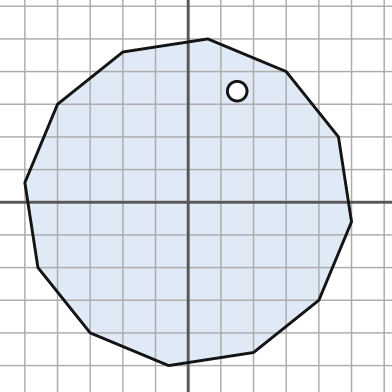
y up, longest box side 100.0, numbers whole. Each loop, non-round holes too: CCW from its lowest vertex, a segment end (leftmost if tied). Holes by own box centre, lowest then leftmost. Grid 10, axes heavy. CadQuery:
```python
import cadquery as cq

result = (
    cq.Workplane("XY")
    .moveTo(-6.0, -50.0)
    .lineTo(20.0, -46.0)
    .lineTo(40.0, -30.0)
    .lineTo(50.0, -6.0)
    .lineTo(46.0, 20.0)
    .lineTo(30.0, 40.0)
    .lineTo(6.0, 50.0)
    .lineTo(-20.0, 46.0)
    .lineTo(-40.0, 30.0)
    .lineTo(-50.0, 6.0)
    .lineTo(-46.0, -20.0)
    .lineTo(-30.0, -40.0)
    .close()
    .moveTo(15.0, 34.0)
    .circle(3.0)
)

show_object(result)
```